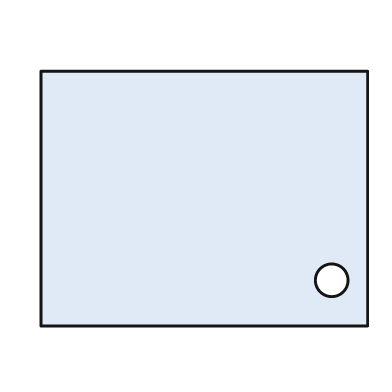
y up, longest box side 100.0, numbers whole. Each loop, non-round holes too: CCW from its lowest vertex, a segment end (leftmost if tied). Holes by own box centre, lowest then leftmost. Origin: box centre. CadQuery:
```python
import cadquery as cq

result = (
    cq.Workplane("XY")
    .moveTo(-50.0, -39.0)
    .lineTo(50.0, -39.0)
    .lineTo(50.0, 39.0)
    .lineTo(-50.0, 39.0)
    .close()
    .moveTo(39.0, -25.0)
    .circle(5.0)
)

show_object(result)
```